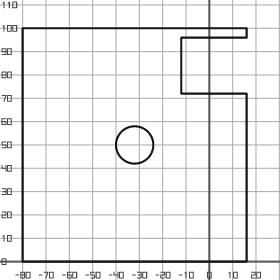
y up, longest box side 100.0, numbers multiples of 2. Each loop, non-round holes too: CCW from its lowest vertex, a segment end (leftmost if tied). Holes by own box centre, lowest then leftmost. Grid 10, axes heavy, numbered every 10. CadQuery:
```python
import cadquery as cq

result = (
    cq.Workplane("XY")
    .moveTo(-80.0, 0.0)
    .lineTo(16.0, 0.0)
    .lineTo(16.0, 72.0)
    .lineTo(-12.0, 72.0)
    .lineTo(-12.0, 96.0)
    .lineTo(16.0, 96.0)
    .lineTo(16.0, 100.0)
    .lineTo(-80.0, 100.0)
    .close()
    .moveTo(-32.0, 50.0)
    .circle(8.0)
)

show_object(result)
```